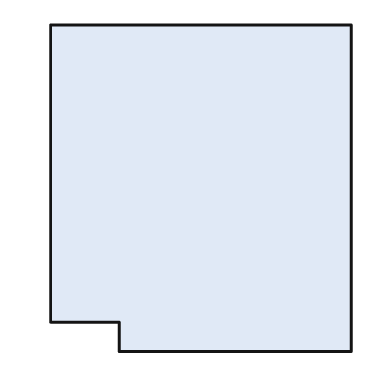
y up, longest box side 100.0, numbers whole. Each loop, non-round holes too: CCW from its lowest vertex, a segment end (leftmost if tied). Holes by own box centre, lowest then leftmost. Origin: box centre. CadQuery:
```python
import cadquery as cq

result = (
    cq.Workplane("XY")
    .moveTo(-25.0, -50.0)
    .lineTo(46.0, -50.0)
    .lineTo(46.0, 50.0)
    .lineTo(-46.0, 50.0)
    .lineTo(-46.0, -41.0)
    .lineTo(-25.0, -41.0)
    .close()
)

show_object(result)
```